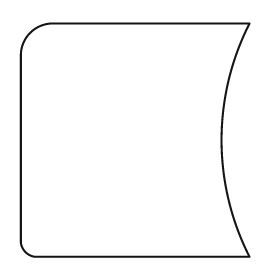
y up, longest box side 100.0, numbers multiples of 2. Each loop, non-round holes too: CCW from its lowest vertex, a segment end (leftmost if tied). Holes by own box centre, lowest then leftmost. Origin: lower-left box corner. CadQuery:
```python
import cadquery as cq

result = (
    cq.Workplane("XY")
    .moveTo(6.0, 0.0)
    .lineTo(98.0, 0.0)
    .threePointArc((86.0, 50.0), (98.0, 100.0))
    .lineTo(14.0, 100.0)
    .threePointArc((4.0, 96.0), (0.0, 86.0))
    .lineTo(0.0, 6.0)
    .threePointArc((2.0, 2.0), (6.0, 0.0))
    .close()
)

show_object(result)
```